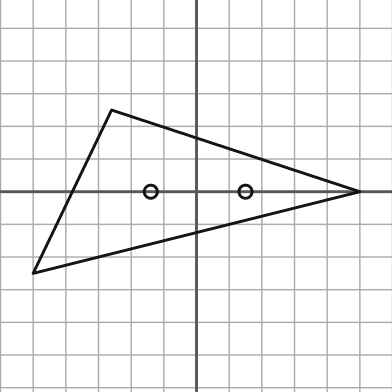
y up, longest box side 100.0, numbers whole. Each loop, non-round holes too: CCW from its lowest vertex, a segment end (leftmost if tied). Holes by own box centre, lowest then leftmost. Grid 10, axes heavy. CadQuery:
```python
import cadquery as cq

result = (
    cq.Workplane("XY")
    .moveTo(-50.0, -25.0)
    .lineTo(50.0, 0.0)
    .lineTo(-26.0, 25.0)
    .close()
    .moveTo(-14.0, 0.0)
    .circle(2.0)
    .moveTo(15.0, 0.0)
    .circle(2.0)
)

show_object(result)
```